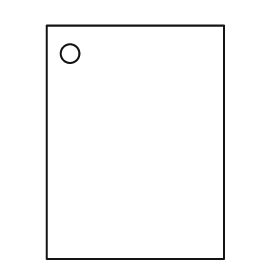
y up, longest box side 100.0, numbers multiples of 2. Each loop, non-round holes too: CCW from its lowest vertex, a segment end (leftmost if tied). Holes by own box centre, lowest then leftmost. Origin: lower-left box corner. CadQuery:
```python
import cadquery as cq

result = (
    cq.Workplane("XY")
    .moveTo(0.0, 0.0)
    .lineTo(76.0, 0.0)
    .lineTo(76.0, 100.0)
    .lineTo(0.0, 100.0)
    .close()
    .moveTo(10.0, 88.0)
    .circle(4.0)
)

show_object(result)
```